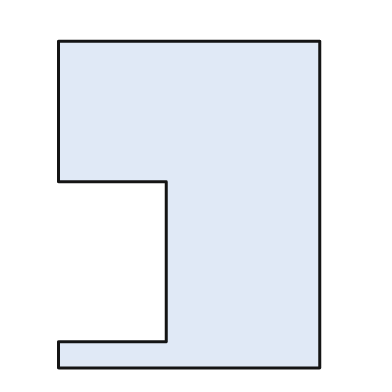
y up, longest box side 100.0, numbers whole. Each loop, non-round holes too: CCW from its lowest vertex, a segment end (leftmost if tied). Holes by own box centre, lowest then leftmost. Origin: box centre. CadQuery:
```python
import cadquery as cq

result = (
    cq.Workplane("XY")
    .moveTo(-40.0, -50.0)
    .lineTo(40.0, -50.0)
    .lineTo(40.0, 50.0)
    .lineTo(-40.0, 50.0)
    .lineTo(-40.0, 7.0)
    .lineTo(-7.0, 7.0)
    .lineTo(-7.0, -42.0)
    .lineTo(-40.0, -42.0)
    .close()
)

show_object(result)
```